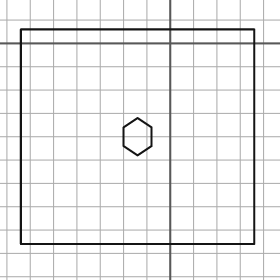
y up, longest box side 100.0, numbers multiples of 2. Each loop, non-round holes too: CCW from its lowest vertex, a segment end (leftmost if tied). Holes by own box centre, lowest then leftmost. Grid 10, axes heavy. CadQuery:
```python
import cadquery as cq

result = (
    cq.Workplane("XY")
    .moveTo(-64.0, -86.0)
    .lineTo(36.0, -86.0)
    .lineTo(36.0, 6.0)
    .lineTo(-64.0, 6.0)
    .close()
    .moveTo(-14.0, -48.0)
    .lineTo(-8.0, -44.0)
    .lineTo(-8.0, -36.0)
    .lineTo(-14.0, -32.0)
    .lineTo(-20.0, -36.0)
    .lineTo(-20.0, -44.0)
    .close()
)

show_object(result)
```